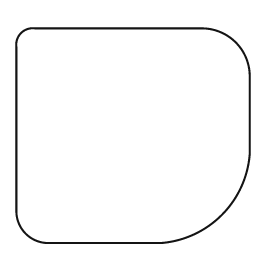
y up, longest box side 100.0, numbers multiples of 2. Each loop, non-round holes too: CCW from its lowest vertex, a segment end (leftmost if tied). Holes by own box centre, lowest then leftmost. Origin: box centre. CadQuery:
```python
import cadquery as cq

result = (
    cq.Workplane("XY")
    .moveTo(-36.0, -46.0)
    .lineTo(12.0, -46.0)
    .threePointArc((38.0, -34.0), (50.0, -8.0))
    .lineTo(50.0, 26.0)
    .threePointArc((44.0, 40.0), (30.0, 46.0))
    .lineTo(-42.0, 46.0)
    .threePointArc((-48.0, 44.0), (-50.0, 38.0))
    .lineTo(-50.0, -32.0)
    .threePointArc((-46.0, -42.0), (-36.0, -46.0))
    .close()
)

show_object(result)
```